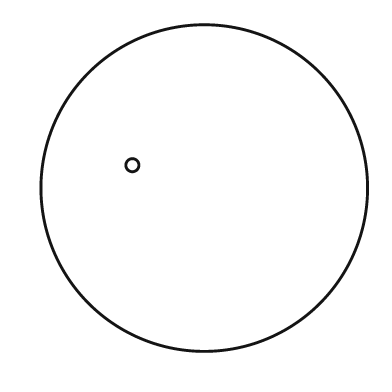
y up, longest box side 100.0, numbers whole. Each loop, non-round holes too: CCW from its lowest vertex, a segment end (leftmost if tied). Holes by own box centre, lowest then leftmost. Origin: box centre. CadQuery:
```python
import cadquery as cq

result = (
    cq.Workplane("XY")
    .moveTo(0.0, 0.0)
    .circle(50.0)
    .moveTo(-22.0, 7.0)
    .circle(2.0)
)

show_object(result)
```